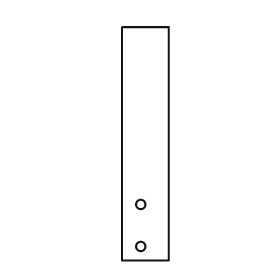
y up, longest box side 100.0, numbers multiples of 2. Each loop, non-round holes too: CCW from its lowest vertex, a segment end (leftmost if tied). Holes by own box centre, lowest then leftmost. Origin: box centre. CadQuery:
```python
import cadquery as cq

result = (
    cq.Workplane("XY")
    .moveTo(-10.0, -50.0)
    .lineTo(10.0, -50.0)
    .lineTo(10.0, 50.0)
    .lineTo(-10.0, 50.0)
    .close()
    .moveTo(-2.0, -44.0)
    .circle(2.0)
    .moveTo(-2.0, -26.0)
    .circle(2.0)
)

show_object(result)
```